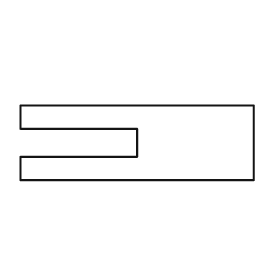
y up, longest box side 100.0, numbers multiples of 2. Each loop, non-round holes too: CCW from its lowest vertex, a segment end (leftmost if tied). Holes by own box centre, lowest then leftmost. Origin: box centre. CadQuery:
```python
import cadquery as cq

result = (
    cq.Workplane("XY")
    .moveTo(-50.0, -16.0)
    .lineTo(50.0, -16.0)
    .lineTo(50.0, 16.0)
    .lineTo(-50.0, 16.0)
    .lineTo(-50.0, 6.0)
    .lineTo(0.0, 6.0)
    .lineTo(0.0, -6.0)
    .lineTo(-50.0, -6.0)
    .close()
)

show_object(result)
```